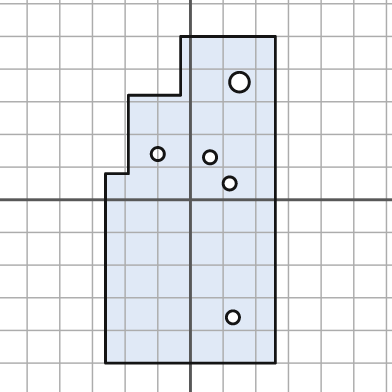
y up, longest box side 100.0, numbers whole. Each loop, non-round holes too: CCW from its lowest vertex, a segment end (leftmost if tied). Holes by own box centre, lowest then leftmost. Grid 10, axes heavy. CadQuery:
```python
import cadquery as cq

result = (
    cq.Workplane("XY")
    .moveTo(-26.0, -50.0)
    .lineTo(26.0, -50.0)
    .lineTo(26.0, 50.0)
    .lineTo(-3.0, 50.0)
    .lineTo(-3.0, 32.0)
    .lineTo(-19.0, 32.0)
    .lineTo(-19.0, 8.0)
    .lineTo(-26.0, 8.0)
    .close()
    .moveTo(13.0, -36.0)
    .circle(2.0)
    .moveTo(12.0, 5.0)
    .circle(2.0)
    .moveTo(6.0, 13.0)
    .circle(2.0)
    .moveTo(-10.0, 14.0)
    .circle(2.0)
    .moveTo(15.0, 36.0)
    .circle(3.0)
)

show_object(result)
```